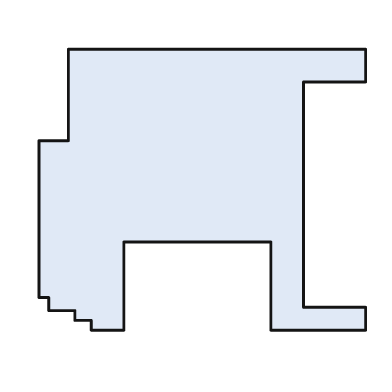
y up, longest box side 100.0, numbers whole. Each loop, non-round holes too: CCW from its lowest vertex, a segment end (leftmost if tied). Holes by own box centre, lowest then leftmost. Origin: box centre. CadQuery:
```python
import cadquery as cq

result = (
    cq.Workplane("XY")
    .moveTo(-34.0, -43.0)
    .lineTo(-24.0, -43.0)
    .lineTo(-24.0, -16.0)
    .lineTo(21.0, -16.0)
    .lineTo(21.0, -43.0)
    .lineTo(50.0, -43.0)
    .lineTo(50.0, -36.0)
    .lineTo(31.0, -36.0)
    .lineTo(31.0, 33.0)
    .lineTo(50.0, 33.0)
    .lineTo(50.0, 43.0)
    .lineTo(-41.0, 43.0)
    .lineTo(-41.0, 15.0)
    .lineTo(-50.0, 15.0)
    .lineTo(-50.0, -33.0)
    .lineTo(-47.0, -33.0)
    .lineTo(-47.0, -37.0)
    .lineTo(-39.0, -37.0)
    .lineTo(-39.0, -40.0)
    .lineTo(-34.0, -40.0)
    .close()
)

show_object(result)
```